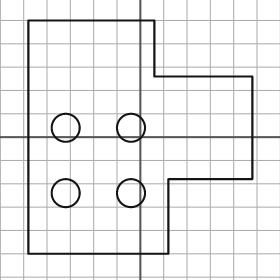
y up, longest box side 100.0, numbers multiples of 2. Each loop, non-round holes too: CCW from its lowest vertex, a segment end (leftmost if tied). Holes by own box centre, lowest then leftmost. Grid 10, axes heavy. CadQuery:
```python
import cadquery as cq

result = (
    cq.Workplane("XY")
    .moveTo(-48.0, -50.0)
    .lineTo(12.0, -50.0)
    .lineTo(12.0, -18.0)
    .lineTo(48.0, -18.0)
    .lineTo(48.0, 26.0)
    .lineTo(6.0, 26.0)
    .lineTo(6.0, 50.0)
    .lineTo(-48.0, 50.0)
    .close()
    .moveTo(-32.0, -24.0)
    .circle(6.0)
    .moveTo(-4.0, -24.0)
    .circle(6.0)
    .moveTo(-32.0, 4.0)
    .circle(6.0)
    .moveTo(-4.0, 4.0)
    .circle(6.0)
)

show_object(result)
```